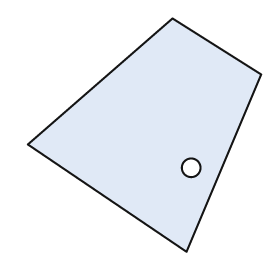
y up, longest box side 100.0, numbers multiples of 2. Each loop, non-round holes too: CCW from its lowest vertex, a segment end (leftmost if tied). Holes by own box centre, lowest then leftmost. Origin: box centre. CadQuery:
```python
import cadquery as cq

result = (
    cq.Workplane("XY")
    .moveTo(18.0, -50.0)
    .lineTo(50.0, 26.0)
    .lineTo(12.0, 50.0)
    .lineTo(-50.0, -4.0)
    .close()
    .moveTo(20.0, -14.0)
    .circle(4.0)
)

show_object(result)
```